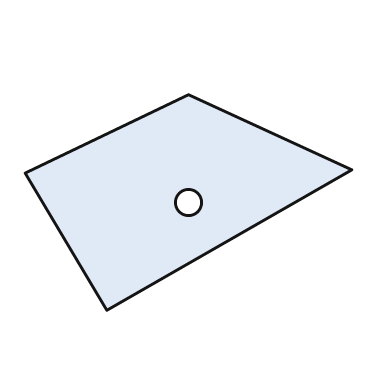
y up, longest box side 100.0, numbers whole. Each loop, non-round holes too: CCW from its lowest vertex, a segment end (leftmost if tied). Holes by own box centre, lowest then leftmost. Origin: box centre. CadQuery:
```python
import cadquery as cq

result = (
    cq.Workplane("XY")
    .moveTo(-25.0, -33.0)
    .lineTo(50.0, 10.0)
    .lineTo(0.0, 33.0)
    .lineTo(-50.0, 9.0)
    .close()
    .moveTo(0.0, 0.0)
    .circle(4.0)
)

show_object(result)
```